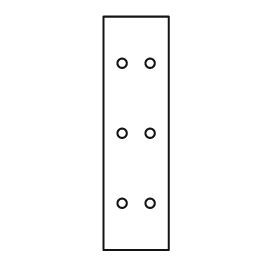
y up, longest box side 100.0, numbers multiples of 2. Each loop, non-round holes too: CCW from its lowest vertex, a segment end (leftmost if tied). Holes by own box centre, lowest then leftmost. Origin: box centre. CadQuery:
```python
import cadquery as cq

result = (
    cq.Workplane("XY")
    .moveTo(-14.0, -50.0)
    .lineTo(14.0, -50.0)
    .lineTo(14.0, 50.0)
    .lineTo(-14.0, 50.0)
    .close()
    .moveTo(-6.0, -30.0)
    .circle(2.0)
    .moveTo(6.0, -30.0)
    .circle(2.0)
    .moveTo(-6.0, 0.0)
    .circle(2.0)
    .moveTo(6.0, 0.0)
    .circle(2.0)
    .moveTo(-6.0, 30.0)
    .circle(2.0)
    .moveTo(6.0, 30.0)
    .circle(2.0)
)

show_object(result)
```